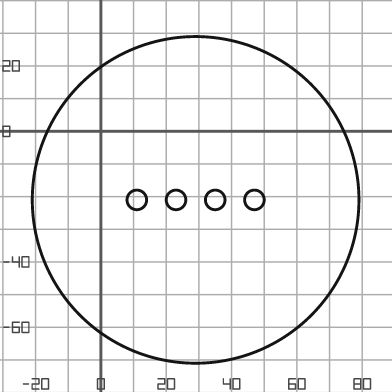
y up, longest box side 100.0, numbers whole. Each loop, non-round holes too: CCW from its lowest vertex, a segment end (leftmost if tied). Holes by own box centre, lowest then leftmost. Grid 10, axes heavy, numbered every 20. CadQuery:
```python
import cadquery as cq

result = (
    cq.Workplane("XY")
    .moveTo(29.0, -21.0)
    .circle(50.0)
    .moveTo(11.0, -21.0)
    .circle(3.0)
    .moveTo(23.0, -21.0)
    .circle(3.0)
    .moveTo(35.0, -21.0)
    .circle(3.0)
    .moveTo(47.0, -21.0)
    .circle(3.0)
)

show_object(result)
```